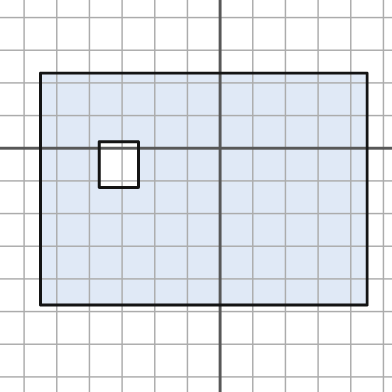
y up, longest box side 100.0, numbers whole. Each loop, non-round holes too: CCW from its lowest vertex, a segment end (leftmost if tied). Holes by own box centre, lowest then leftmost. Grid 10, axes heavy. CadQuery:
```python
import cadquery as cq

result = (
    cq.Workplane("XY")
    .moveTo(-55.0, -48.0)
    .lineTo(45.0, -48.0)
    .lineTo(45.0, 23.0)
    .lineTo(-55.0, 23.0)
    .close()
    .moveTo(-37.0, -12.0)
    .lineTo(-25.0, -12.0)
    .lineTo(-25.0, 2.0)
    .lineTo(-37.0, 2.0)
    .close()
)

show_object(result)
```